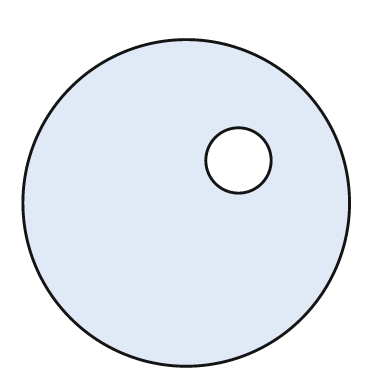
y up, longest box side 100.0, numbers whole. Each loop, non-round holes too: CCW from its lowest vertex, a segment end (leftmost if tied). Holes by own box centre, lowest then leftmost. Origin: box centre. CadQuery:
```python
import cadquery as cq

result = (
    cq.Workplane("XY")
    .moveTo(0.0, 0.0)
    .circle(50.0)
    .moveTo(16.0, 13.0)
    .circle(10.0)
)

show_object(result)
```